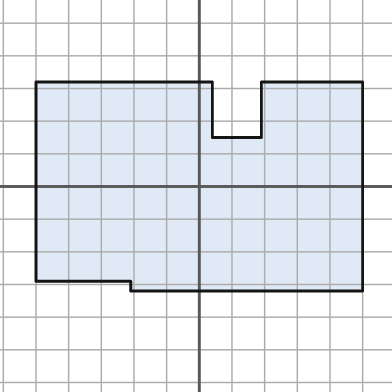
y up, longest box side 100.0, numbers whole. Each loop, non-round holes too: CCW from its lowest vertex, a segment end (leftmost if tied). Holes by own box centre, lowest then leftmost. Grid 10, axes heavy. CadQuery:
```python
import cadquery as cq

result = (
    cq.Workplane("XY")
    .moveTo(-21.0, -32.0)
    .lineTo(50.0, -32.0)
    .lineTo(50.0, 32.0)
    .lineTo(19.0, 32.0)
    .lineTo(19.0, 15.0)
    .lineTo(4.0, 15.0)
    .lineTo(4.0, 32.0)
    .lineTo(-50.0, 32.0)
    .lineTo(-50.0, -29.0)
    .lineTo(-21.0, -29.0)
    .close()
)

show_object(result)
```